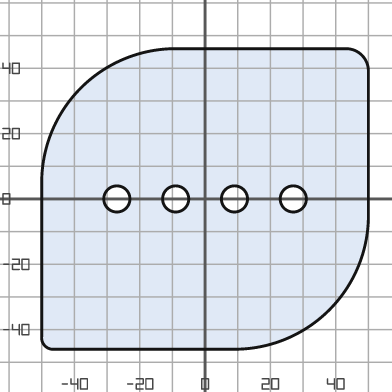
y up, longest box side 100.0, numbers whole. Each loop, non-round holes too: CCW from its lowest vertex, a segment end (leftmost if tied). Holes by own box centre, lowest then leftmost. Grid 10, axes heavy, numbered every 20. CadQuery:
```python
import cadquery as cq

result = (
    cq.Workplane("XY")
    .moveTo(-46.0, -46.0)
    .lineTo(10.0, -46.0)
    .threePointArc((38.0, -34.0), (50.0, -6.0))
    .lineTo(50.0, 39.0)
    .threePointArc((48.0, 44.0), (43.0, 46.0))
    .lineTo(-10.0, 46.0)
    .threePointArc((-38.0, 34.0), (-50.0, 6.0))
    .lineTo(-50.0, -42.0)
    .threePointArc((-49.0, -45.0), (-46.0, -46.0))
    .close()
    .moveTo(-27.0, 0.0)
    .circle(4.0)
    .moveTo(-9.0, 0.0)
    .circle(4.0)
    .moveTo(9.0, 0.0)
    .circle(4.0)
    .moveTo(27.0, 0.0)
    .circle(4.0)
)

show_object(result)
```